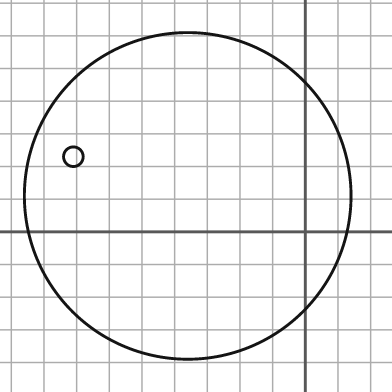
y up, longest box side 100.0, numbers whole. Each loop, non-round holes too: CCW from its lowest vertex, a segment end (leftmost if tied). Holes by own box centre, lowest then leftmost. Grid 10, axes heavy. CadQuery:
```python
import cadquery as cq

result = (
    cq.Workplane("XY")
    .moveTo(-36.0, 11.0)
    .circle(50.0)
    .moveTo(-71.0, 23.0)
    .circle(3.0)
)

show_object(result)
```